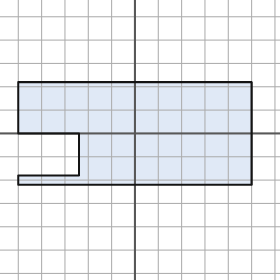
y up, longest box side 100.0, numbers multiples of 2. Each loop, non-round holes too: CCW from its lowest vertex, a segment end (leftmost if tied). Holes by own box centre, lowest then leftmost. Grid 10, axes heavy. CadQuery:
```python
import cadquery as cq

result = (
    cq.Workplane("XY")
    .moveTo(-50.0, -22.0)
    .lineTo(50.0, -22.0)
    .lineTo(50.0, 22.0)
    .lineTo(-50.0, 22.0)
    .lineTo(-50.0, 0.0)
    .lineTo(-24.0, 0.0)
    .lineTo(-24.0, -18.0)
    .lineTo(-50.0, -18.0)
    .close()
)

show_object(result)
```